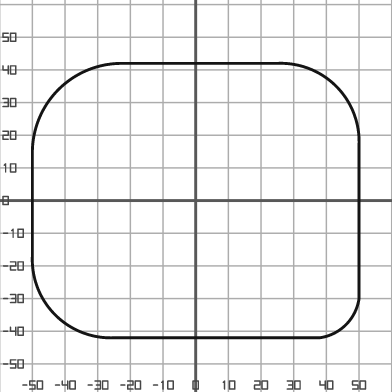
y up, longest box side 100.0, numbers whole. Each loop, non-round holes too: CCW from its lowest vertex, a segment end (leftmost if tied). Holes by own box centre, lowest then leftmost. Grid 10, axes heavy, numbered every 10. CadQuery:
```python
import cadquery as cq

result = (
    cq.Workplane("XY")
    .moveTo(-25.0, -42.0)
    .lineTo(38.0, -42.0)
    .threePointArc((46.0, -38.0), (50.0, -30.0))
    .lineTo(50.0, 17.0)
    .threePointArc((43.0, 35.0), (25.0, 42.0))
    .lineTo(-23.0, 42.0)
    .threePointArc((-42.0, 34.0), (-50.0, 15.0))
    .lineTo(-50.0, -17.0)
    .threePointArc((-43.0, -35.0), (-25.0, -42.0))
    .close()
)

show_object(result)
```